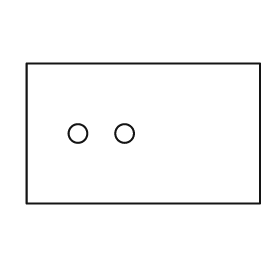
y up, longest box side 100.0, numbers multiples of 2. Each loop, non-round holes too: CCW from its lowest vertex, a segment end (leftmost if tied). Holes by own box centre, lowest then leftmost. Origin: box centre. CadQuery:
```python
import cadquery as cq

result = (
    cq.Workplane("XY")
    .moveTo(-50.0, -30.0)
    .lineTo(50.0, -30.0)
    .lineTo(50.0, 30.0)
    .lineTo(-50.0, 30.0)
    .close()
    .moveTo(-28.0, 0.0)
    .circle(4.0)
    .moveTo(-8.0, 0.0)
    .circle(4.0)
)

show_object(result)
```